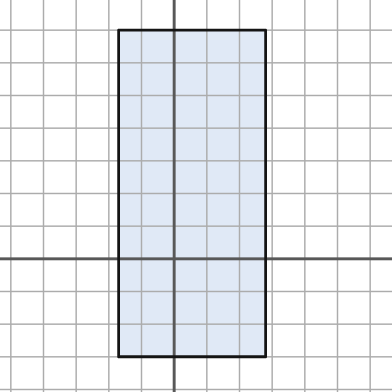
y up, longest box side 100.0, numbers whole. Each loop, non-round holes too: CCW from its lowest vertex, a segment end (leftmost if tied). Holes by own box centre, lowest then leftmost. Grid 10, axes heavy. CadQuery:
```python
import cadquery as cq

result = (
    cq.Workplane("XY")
    .moveTo(-17.0, -30.0)
    .lineTo(28.0, -30.0)
    .lineTo(28.0, 70.0)
    .lineTo(-17.0, 70.0)
    .close()
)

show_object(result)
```